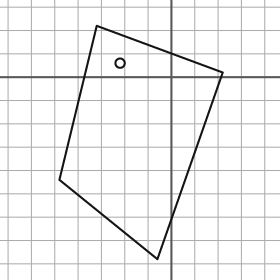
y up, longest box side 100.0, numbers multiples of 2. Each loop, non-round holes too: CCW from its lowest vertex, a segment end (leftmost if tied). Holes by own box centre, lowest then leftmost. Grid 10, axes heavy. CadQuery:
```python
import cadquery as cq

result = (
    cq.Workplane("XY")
    .moveTo(-6.0, -78.0)
    .lineTo(22.0, 2.0)
    .lineTo(-32.0, 22.0)
    .lineTo(-48.0, -44.0)
    .close()
    .moveTo(-22.0, 6.0)
    .circle(2.0)
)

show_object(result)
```